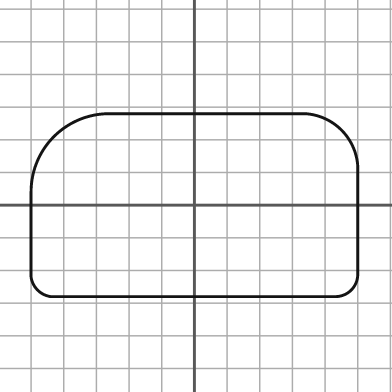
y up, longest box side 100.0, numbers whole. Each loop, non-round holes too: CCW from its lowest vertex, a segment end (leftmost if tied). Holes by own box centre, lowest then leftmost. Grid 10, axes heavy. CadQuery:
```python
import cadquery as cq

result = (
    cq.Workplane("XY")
    .moveTo(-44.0, -28.0)
    .lineTo(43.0, -28.0)
    .threePointArc((48.0, -26.0), (50.0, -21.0))
    .lineTo(50.0, 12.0)
    .threePointArc((45.0, 23.0), (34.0, 28.0))
    .lineTo(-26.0, 28.0)
    .threePointArc((-43.0, 21.0), (-50.0, 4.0))
    .lineTo(-50.0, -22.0)
    .threePointArc((-48.0, -26.0), (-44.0, -28.0))
    .close()
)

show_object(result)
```